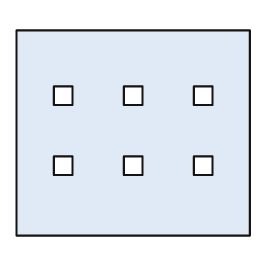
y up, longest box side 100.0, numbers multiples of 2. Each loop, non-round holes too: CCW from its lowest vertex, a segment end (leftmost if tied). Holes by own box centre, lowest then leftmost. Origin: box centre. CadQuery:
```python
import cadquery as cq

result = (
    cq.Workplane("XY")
    .moveTo(-50.0, -44.0)
    .lineTo(50.0, -44.0)
    .lineTo(50.0, 44.0)
    .lineTo(-50.0, 44.0)
    .close()
    .moveTo(-34.0, -18.0)
    .lineTo(-26.0, -18.0)
    .lineTo(-26.0, -10.0)
    .lineTo(-34.0, -10.0)
    .close()
    .moveTo(-4.0, -18.0)
    .lineTo(4.0, -18.0)
    .lineTo(4.0, -10.0)
    .lineTo(-4.0, -10.0)
    .close()
    .moveTo(26.0, -18.0)
    .lineTo(34.0, -18.0)
    .lineTo(34.0, -10.0)
    .lineTo(26.0, -10.0)
    .close()
    .moveTo(-34.0, 12.0)
    .lineTo(-26.0, 12.0)
    .lineTo(-26.0, 20.0)
    .lineTo(-34.0, 20.0)
    .close()
    .moveTo(-4.0, 12.0)
    .lineTo(4.0, 12.0)
    .lineTo(4.0, 20.0)
    .lineTo(-4.0, 20.0)
    .close()
    .moveTo(26.0, 12.0)
    .lineTo(34.0, 12.0)
    .lineTo(34.0, 20.0)
    .lineTo(26.0, 20.0)
    .close()
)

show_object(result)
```